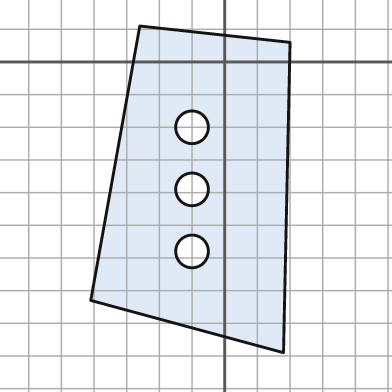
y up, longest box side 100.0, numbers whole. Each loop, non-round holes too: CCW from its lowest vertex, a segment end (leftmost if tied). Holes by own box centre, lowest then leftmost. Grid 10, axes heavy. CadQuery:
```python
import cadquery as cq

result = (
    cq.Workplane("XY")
    .moveTo(18.0, -89.0)
    .lineTo(20.0, 6.0)
    .lineTo(-26.0, 11.0)
    .lineTo(-41.0, -73.0)
    .close()
    .moveTo(-10.0, -58.0)
    .circle(5.0)
    .moveTo(-10.0, -39.0)
    .circle(5.0)
    .moveTo(-10.0, -20.0)
    .circle(5.0)
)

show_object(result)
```